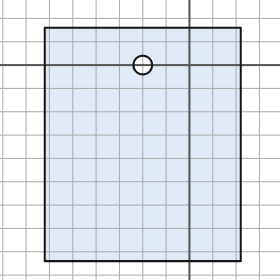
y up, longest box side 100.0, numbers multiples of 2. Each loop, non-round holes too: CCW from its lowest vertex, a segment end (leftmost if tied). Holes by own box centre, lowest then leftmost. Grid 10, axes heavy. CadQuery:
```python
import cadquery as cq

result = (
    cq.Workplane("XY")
    .moveTo(-62.0, -84.0)
    .lineTo(22.0, -84.0)
    .lineTo(22.0, 16.0)
    .lineTo(-62.0, 16.0)
    .close()
    .moveTo(-20.0, 0.0)
    .circle(4.0)
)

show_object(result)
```